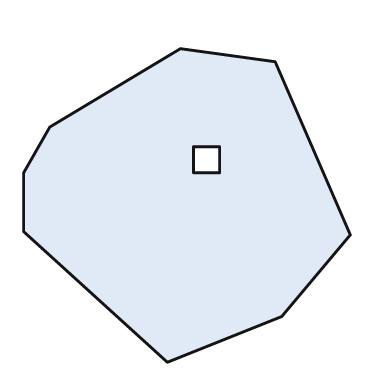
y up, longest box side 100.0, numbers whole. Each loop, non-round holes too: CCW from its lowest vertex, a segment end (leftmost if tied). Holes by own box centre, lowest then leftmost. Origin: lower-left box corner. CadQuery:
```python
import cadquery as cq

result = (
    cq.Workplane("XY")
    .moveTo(44.0, 0.0)
    .lineTo(79.0, 14.0)
    .lineTo(100.0, 39.0)
    .lineTo(77.0, 92.0)
    .lineTo(48.0, 96.0)
    .lineTo(8.0, 72.0)
    .lineTo(0.0, 58.0)
    .lineTo(0.0, 40.0)
    .close()
    .moveTo(52.0, 58.0)
    .lineTo(60.0, 58.0)
    .lineTo(60.0, 66.0)
    .lineTo(52.0, 66.0)
    .close()
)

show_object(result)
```